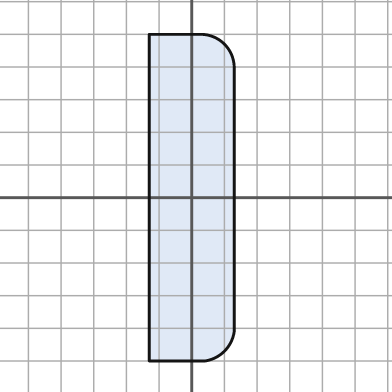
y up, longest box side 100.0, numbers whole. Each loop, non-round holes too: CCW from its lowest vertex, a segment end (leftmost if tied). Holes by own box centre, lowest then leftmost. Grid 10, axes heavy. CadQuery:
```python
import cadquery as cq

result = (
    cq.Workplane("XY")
    .moveTo(-13.0, -50.0)
    .lineTo(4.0, -50.0)
    .threePointArc((10.0, -47.0), (13.0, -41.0))
    .lineTo(13.0, 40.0)
    .threePointArc((10.0, 47.0), (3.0, 50.0))
    .lineTo(-13.0, 50.0)
    .close()
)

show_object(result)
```